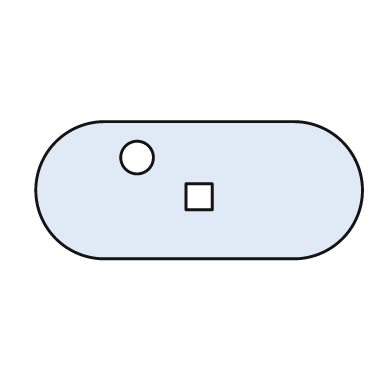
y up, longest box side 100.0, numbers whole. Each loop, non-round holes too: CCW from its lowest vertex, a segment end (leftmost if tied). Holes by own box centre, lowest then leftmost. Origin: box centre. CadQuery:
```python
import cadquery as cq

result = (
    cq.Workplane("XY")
    .moveTo(-29.0, -21.0)
    .lineTo(29.0, -21.0)
    .threePointArc((50.0, 0.0), (29.0, 21.0))
    .lineTo(-29.0, 21.0)
    .threePointArc((-50.0, 0.0), (-29.0, -21.0))
    .close()
    .moveTo(-4.0, -6.0)
    .lineTo(4.0, -6.0)
    .lineTo(4.0, 2.0)
    .lineTo(-4.0, 2.0)
    .close()
    .moveTo(-19.0, 10.0)
    .circle(5.0)
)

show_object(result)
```